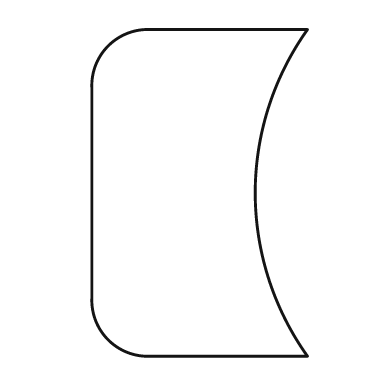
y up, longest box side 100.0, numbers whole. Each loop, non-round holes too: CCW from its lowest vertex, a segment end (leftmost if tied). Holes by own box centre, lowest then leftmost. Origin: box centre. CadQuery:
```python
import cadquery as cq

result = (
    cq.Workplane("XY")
    .moveTo(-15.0, -50.0)
    .lineTo(33.0, -50.0)
    .threePointArc((17.0, 0.0), (33.0, 50.0))
    .lineTo(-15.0, 50.0)
    .threePointArc((-28.0, 45.0), (-33.0, 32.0))
    .lineTo(-33.0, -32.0)
    .threePointArc((-28.0, -45.0), (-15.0, -50.0))
    .close()
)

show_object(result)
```